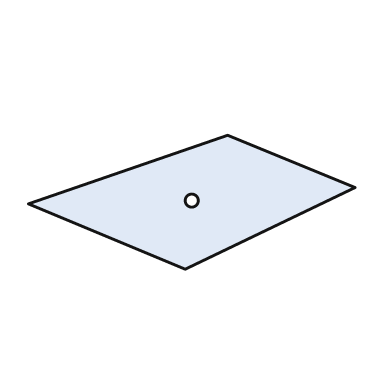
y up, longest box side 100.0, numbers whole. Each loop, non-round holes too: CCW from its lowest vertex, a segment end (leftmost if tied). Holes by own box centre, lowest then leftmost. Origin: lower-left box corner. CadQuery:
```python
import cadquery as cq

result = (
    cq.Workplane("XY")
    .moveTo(48.0, 0.0)
    .lineTo(100.0, 25.0)
    .lineTo(61.0, 41.0)
    .lineTo(0.0, 20.0)
    .close()
    .moveTo(50.0, 21.0)
    .circle(2.0)
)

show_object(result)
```